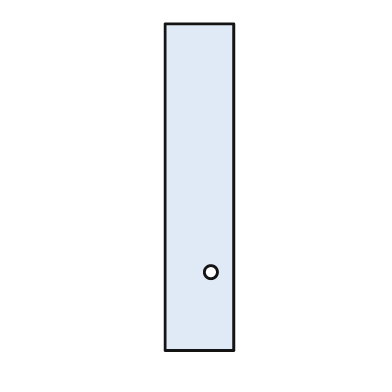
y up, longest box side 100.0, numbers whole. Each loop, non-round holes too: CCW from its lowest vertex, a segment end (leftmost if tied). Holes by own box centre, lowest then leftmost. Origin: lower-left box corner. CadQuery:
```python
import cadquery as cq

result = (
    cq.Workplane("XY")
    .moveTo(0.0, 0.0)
    .lineTo(21.0, 0.0)
    .lineTo(21.0, 100.0)
    .lineTo(0.0, 100.0)
    .close()
    .moveTo(14.0, 24.0)
    .circle(2.0)
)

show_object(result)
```